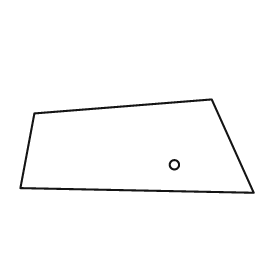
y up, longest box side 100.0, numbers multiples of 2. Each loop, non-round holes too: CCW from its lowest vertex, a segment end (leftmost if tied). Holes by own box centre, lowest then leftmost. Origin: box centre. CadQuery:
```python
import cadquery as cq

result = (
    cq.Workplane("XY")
    .moveTo(50.0, -20.0)
    .lineTo(32.0, 20.0)
    .lineTo(-44.0, 14.0)
    .lineTo(-50.0, -18.0)
    .close()
    .moveTo(16.0, -8.0)
    .circle(2.0)
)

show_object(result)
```